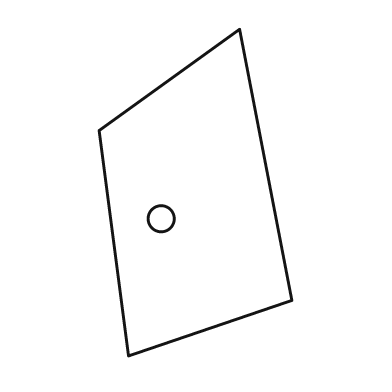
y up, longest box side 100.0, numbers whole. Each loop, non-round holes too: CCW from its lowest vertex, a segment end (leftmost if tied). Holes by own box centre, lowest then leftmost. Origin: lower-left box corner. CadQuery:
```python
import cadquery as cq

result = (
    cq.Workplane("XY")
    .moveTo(9.0, 0.0)
    .lineTo(59.0, 17.0)
    .lineTo(43.0, 100.0)
    .lineTo(0.0, 69.0)
    .close()
    .moveTo(19.0, 42.0)
    .circle(4.0)
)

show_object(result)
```